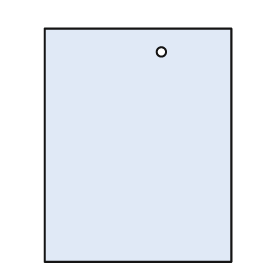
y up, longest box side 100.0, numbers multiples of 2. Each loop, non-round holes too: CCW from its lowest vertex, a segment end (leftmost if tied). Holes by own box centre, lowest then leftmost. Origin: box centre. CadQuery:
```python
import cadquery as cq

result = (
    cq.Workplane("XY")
    .moveTo(-40.0, -50.0)
    .lineTo(40.0, -50.0)
    .lineTo(40.0, 50.0)
    .lineTo(-40.0, 50.0)
    .close()
    .moveTo(10.0, 40.0)
    .circle(2.0)
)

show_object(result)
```